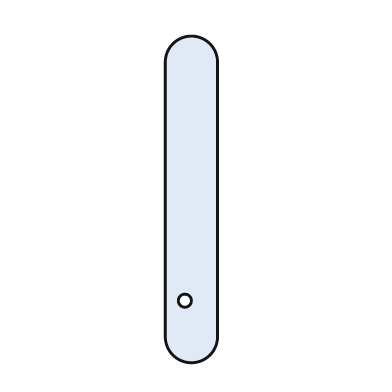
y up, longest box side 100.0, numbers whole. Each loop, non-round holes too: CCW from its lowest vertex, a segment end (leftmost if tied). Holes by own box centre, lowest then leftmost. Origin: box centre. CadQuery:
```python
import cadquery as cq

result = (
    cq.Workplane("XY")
    .moveTo(-8.0, -42.0)
    .threePointArc((0.0, -50.0), (8.0, -42.0))
    .lineTo(8.0, 42.0)
    .threePointArc((0.0, 50.0), (-8.0, 42.0))
    .close()
    .moveTo(-2.0, -31.0)
    .circle(2.0)
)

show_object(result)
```